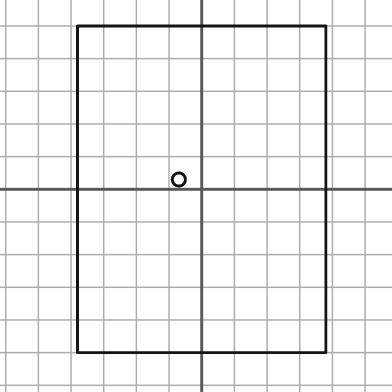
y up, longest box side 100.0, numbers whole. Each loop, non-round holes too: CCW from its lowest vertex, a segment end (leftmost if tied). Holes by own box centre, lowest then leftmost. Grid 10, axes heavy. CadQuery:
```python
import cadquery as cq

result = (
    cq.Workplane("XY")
    .moveTo(-38.0, -50.0)
    .lineTo(38.0, -50.0)
    .lineTo(38.0, 50.0)
    .lineTo(-38.0, 50.0)
    .close()
    .moveTo(-7.0, 3.0)
    .circle(2.0)
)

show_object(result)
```